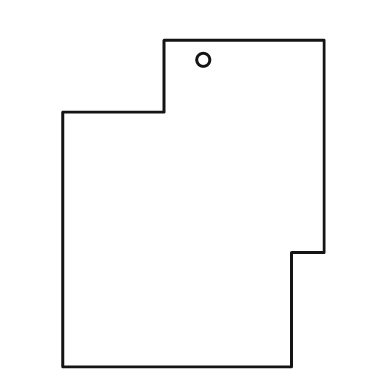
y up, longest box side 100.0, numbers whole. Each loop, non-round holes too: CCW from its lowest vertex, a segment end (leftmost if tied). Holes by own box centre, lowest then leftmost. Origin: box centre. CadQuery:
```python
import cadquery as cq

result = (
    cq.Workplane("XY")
    .moveTo(-40.0, -50.0)
    .lineTo(30.0, -50.0)
    .lineTo(30.0, -15.0)
    .lineTo(40.0, -15.0)
    .lineTo(40.0, 50.0)
    .lineTo(-9.0, 50.0)
    .lineTo(-9.0, 28.0)
    .lineTo(-40.0, 28.0)
    .close()
    .moveTo(3.0, 44.0)
    .circle(2.0)
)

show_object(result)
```